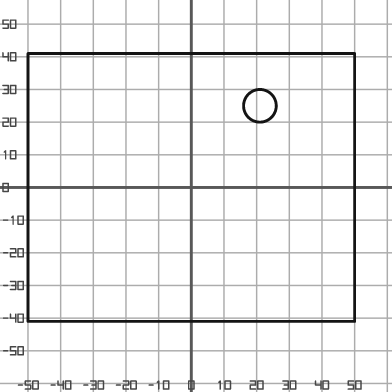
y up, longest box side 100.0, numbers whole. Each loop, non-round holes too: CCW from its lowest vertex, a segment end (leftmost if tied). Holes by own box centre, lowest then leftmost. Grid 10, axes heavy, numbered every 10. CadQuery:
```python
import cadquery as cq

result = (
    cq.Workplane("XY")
    .moveTo(-50.0, -41.0)
    .lineTo(50.0, -41.0)
    .lineTo(50.0, 41.0)
    .lineTo(-50.0, 41.0)
    .close()
    .moveTo(21.0, 25.0)
    .circle(5.0)
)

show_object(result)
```